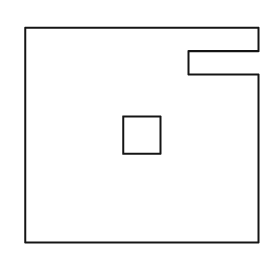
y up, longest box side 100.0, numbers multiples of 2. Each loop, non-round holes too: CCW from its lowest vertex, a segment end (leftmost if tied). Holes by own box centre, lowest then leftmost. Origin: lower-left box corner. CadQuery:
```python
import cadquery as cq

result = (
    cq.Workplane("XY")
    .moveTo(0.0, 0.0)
    .lineTo(100.0, 0.0)
    .lineTo(100.0, 72.0)
    .lineTo(70.0, 72.0)
    .lineTo(70.0, 82.0)
    .lineTo(100.0, 82.0)
    .lineTo(100.0, 92.0)
    .lineTo(0.0, 92.0)
    .close()
    .moveTo(42.0, 38.0)
    .lineTo(58.0, 38.0)
    .lineTo(58.0, 54.0)
    .lineTo(42.0, 54.0)
    .close()
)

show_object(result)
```